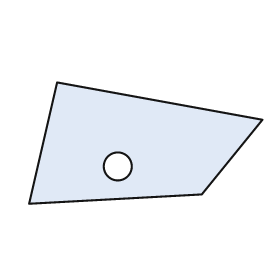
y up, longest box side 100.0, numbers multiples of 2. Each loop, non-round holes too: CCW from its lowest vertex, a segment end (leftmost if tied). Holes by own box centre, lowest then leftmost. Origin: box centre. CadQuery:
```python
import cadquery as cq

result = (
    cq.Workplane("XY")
    .moveTo(-50.0, -26.0)
    .lineTo(24.0, -22.0)
    .lineTo(50.0, 10.0)
    .lineTo(-38.0, 26.0)
    .close()
    .moveTo(-12.0, -10.0)
    .circle(6.0)
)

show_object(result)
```